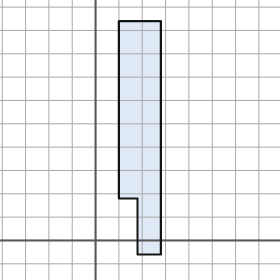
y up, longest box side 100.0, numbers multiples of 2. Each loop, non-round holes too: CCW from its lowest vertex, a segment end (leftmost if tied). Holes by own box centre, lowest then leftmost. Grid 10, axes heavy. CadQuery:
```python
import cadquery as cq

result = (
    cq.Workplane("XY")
    .moveTo(18.0, -6.0)
    .lineTo(28.0, -6.0)
    .lineTo(28.0, 94.0)
    .lineTo(10.0, 94.0)
    .lineTo(10.0, 18.0)
    .lineTo(18.0, 18.0)
    .close()
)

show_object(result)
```